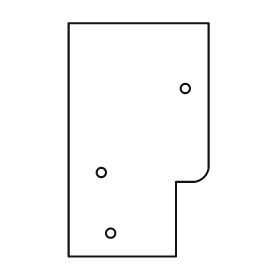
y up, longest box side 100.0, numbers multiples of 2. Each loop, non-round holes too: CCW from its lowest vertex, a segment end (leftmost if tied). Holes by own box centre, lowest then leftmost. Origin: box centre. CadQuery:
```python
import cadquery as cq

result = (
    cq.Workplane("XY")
    .moveTo(-30.0, -50.0)
    .lineTo(16.0, -50.0)
    .lineTo(16.0, -18.0)
    .lineTo(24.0, -18.0)
    .threePointArc((28.0, -16.0), (30.0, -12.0))
    .lineTo(30.0, 50.0)
    .lineTo(-30.0, 50.0)
    .close()
    .moveTo(-12.0, -40.0)
    .circle(2.0)
    .moveTo(-16.0, -14.0)
    .circle(2.0)
    .moveTo(20.0, 22.0)
    .circle(2.0)
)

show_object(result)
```